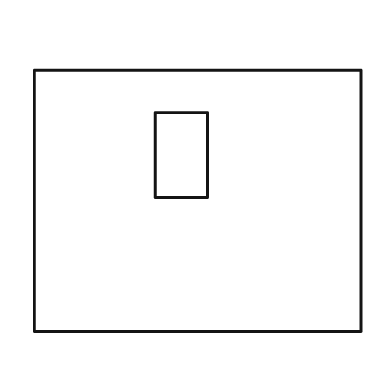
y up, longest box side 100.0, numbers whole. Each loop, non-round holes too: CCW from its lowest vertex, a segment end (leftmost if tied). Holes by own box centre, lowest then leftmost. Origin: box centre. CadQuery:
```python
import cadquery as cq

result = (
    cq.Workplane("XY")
    .moveTo(-50.0, -40.0)
    .lineTo(50.0, -40.0)
    .lineTo(50.0, 40.0)
    .lineTo(-50.0, 40.0)
    .close()
    .moveTo(-13.0, 1.0)
    .lineTo(3.0, 1.0)
    .lineTo(3.0, 27.0)
    .lineTo(-13.0, 27.0)
    .close()
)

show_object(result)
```